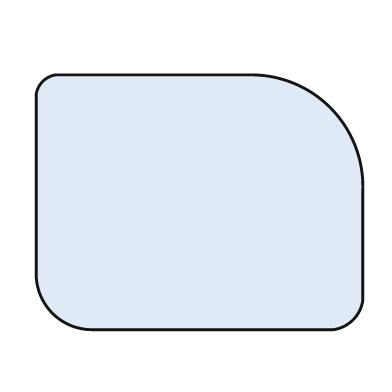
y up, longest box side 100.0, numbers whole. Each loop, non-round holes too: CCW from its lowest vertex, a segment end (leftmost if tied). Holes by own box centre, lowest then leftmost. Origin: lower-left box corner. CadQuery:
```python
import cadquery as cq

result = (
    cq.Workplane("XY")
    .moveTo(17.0, 0.0)
    .lineTo(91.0, 0.0)
    .threePointArc((97.0, 3.0), (100.0, 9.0))
    .lineTo(100.0, 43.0)
    .threePointArc((90.0, 68.0), (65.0, 78.0))
    .lineTo(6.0, 78.0)
    .threePointArc((2.0, 76.0), (0.0, 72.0))
    .lineTo(0.0, 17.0)
    .threePointArc((5.0, 5.0), (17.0, 0.0))
    .close()
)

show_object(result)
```